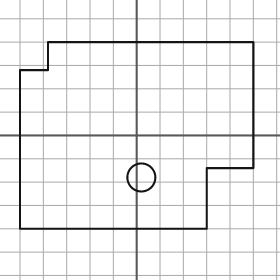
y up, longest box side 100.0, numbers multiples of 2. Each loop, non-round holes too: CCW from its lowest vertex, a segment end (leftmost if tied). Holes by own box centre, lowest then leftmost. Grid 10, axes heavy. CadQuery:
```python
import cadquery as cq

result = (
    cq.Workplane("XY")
    .moveTo(-50.0, -40.0)
    .lineTo(30.0, -40.0)
    .lineTo(30.0, -14.0)
    .lineTo(50.0, -14.0)
    .lineTo(50.0, 40.0)
    .lineTo(-38.0, 40.0)
    .lineTo(-38.0, 28.0)
    .lineTo(-50.0, 28.0)
    .close()
    .moveTo(2.0, -18.0)
    .circle(6.0)
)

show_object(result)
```